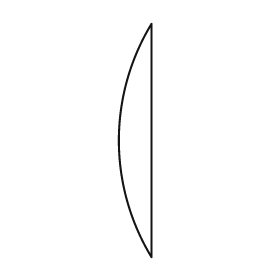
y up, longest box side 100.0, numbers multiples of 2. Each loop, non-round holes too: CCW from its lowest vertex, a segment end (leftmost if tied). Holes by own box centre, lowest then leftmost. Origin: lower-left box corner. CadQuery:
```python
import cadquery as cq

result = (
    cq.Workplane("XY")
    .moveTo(14.0, 0.0)
    .lineTo(14.0, 100.0)
    .threePointArc((0.0, 50.0), (14.0, 0.0))
    .close()
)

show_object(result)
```